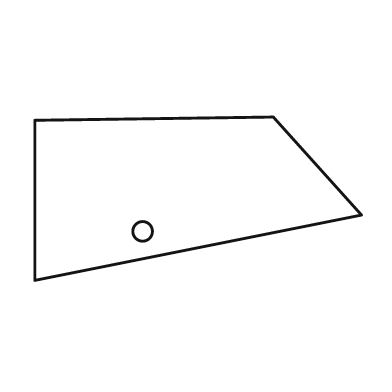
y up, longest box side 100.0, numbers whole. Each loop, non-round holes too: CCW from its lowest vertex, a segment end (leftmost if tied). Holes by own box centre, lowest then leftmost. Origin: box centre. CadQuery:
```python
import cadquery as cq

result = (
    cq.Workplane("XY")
    .moveTo(-50.0, -25.0)
    .lineTo(50.0, -5.0)
    .lineTo(23.0, 25.0)
    .lineTo(-50.0, 24.0)
    .close()
    .moveTo(-17.0, -10.0)
    .circle(3.0)
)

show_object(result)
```